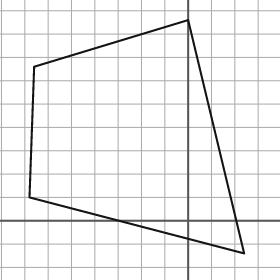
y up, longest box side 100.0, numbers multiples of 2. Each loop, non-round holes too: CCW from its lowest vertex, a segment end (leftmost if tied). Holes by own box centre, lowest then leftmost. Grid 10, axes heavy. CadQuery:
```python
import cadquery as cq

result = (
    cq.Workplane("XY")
    .moveTo(24.0, -14.0)
    .lineTo(0.0, 86.0)
    .lineTo(-66.0, 66.0)
    .lineTo(-68.0, 10.0)
    .close()
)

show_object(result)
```